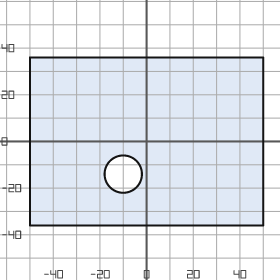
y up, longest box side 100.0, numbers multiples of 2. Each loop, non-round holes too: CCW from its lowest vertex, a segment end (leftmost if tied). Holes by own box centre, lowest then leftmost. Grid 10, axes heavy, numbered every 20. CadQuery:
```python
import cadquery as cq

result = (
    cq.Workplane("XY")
    .moveTo(-50.0, -36.0)
    .lineTo(50.0, -36.0)
    .lineTo(50.0, 36.0)
    .lineTo(-50.0, 36.0)
    .close()
    .moveTo(-10.0, -14.0)
    .circle(8.0)
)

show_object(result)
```